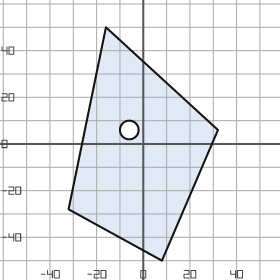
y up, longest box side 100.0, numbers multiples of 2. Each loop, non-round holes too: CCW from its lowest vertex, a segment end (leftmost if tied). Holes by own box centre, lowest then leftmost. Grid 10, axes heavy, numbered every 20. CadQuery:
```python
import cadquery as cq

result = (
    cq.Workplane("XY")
    .moveTo(8.0, -50.0)
    .lineTo(32.0, 6.0)
    .lineTo(-16.0, 50.0)
    .lineTo(-32.0, -28.0)
    .close()
    .moveTo(-6.0, 6.0)
    .circle(4.0)
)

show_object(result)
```